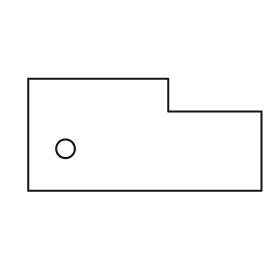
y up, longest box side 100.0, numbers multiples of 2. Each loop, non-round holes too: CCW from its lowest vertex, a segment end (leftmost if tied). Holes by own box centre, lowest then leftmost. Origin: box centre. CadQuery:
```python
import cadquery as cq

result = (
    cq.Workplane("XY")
    .moveTo(-50.0, -24.0)
    .lineTo(50.0, -24.0)
    .lineTo(50.0, 10.0)
    .lineTo(10.0, 10.0)
    .lineTo(10.0, 24.0)
    .lineTo(-50.0, 24.0)
    .close()
    .moveTo(-34.0, -6.0)
    .circle(4.0)
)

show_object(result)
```